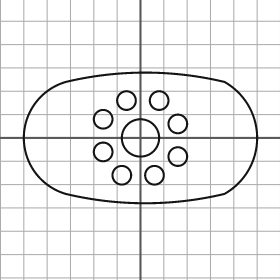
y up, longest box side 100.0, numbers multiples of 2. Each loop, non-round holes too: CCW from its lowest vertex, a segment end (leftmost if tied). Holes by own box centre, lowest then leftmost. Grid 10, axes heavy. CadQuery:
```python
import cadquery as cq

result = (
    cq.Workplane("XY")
    .moveTo(-32.0, -24.0)
    .threePointArc((2.0, -28.0), (36.0, -24.0))
    .threePointArc((50.0, 0.0), (36.0, 24.0))
    .threePointArc((2.0, 28.0), (-32.0, 24.0))
    .threePointArc((-50.0, 0.0), (-32.0, -24.0))
    .close()
    .moveTo(-8.0, -16.0)
    .circle(4.0)
    .moveTo(6.0, -16.0)
    .circle(4.0)
    .moveTo(16.0, -8.0)
    .circle(4.0)
    .moveTo(-16.0, -6.0)
    .circle(4.0)
    .moveTo(0.0, 0.0)
    .circle(8.0)
    .moveTo(16.0, 6.0)
    .circle(4.0)
    .moveTo(-16.0, 8.0)
    .circle(4.0)
    .moveTo(-6.0, 16.0)
    .circle(4.0)
    .moveTo(8.0, 16.0)
    .circle(4.0)
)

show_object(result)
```